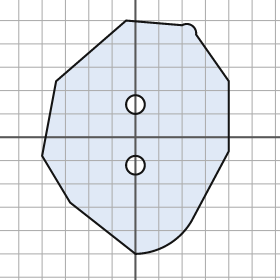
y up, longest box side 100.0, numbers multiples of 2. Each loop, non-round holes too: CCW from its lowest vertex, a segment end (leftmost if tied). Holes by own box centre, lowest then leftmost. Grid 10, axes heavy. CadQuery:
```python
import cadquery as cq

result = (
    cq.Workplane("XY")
    .moveTo(0.0, -50.0)
    .threePointArc((14.0, -46.0), (24.0, -36.0))
    .lineTo(40.0, -6.0)
    .lineTo(40.0, 24.0)
    .lineTo(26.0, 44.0)
    .threePointArc((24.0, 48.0), (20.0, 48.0))
    .lineTo(-4.0, 50.0)
    .lineTo(-34.0, 24.0)
    .lineTo(-40.0, -8.0)
    .lineTo(-28.0, -28.0)
    .close()
    .moveTo(0.0, -12.0)
    .circle(4.0)
    .moveTo(0.0, 14.0)
    .circle(4.0)
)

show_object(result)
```